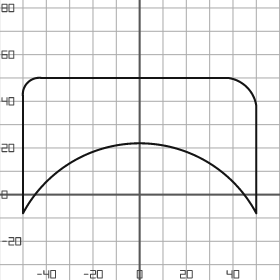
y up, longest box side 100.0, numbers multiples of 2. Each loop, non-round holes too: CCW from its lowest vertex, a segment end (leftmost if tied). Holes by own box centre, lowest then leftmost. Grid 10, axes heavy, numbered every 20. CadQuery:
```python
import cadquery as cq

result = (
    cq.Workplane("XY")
    .moveTo(-50.0, -8.0)
    .threePointArc((0.0, 22.0), (50.0, -8.0))
    .lineTo(50.0, 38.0)
    .threePointArc((46.0, 46.0), (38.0, 50.0))
    .lineTo(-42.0, 50.0)
    .threePointArc((-48.0, 48.0), (-50.0, 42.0))
    .close()
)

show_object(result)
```